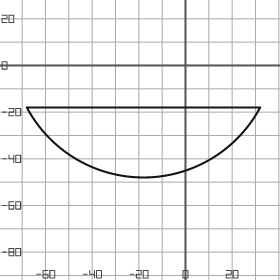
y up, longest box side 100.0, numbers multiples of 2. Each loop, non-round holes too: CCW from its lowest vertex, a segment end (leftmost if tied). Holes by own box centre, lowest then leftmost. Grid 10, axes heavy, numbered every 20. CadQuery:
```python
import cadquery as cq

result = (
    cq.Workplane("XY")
    .moveTo(-68.0, -18.0)
    .threePointArc((-18.0, -48.0), (32.0, -18.0))
    .close()
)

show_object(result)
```